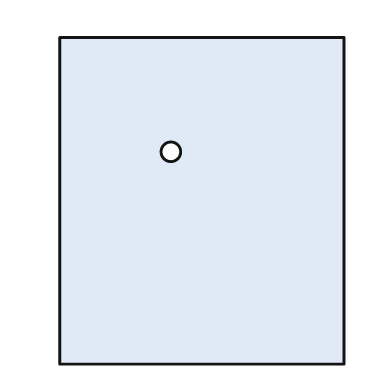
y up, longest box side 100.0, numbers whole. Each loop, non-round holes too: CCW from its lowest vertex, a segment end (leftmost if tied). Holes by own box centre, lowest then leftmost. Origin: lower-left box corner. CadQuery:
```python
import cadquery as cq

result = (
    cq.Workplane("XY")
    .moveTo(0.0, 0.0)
    .lineTo(87.0, 0.0)
    .lineTo(87.0, 100.0)
    .lineTo(0.0, 100.0)
    .close()
    .moveTo(34.0, 65.0)
    .circle(3.0)
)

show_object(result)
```